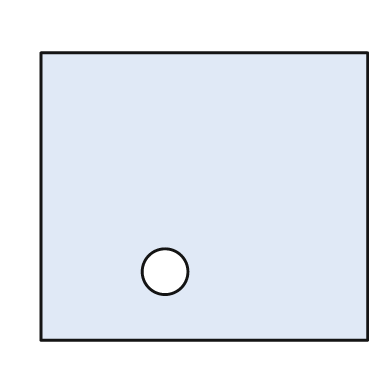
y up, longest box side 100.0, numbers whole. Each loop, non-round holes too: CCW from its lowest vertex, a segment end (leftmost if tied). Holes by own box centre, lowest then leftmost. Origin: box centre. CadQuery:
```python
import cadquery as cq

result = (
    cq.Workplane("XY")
    .moveTo(-50.0, -44.0)
    .lineTo(50.0, -44.0)
    .lineTo(50.0, 44.0)
    .lineTo(-50.0, 44.0)
    .close()
    .moveTo(-12.0, -23.0)
    .circle(7.0)
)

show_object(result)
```